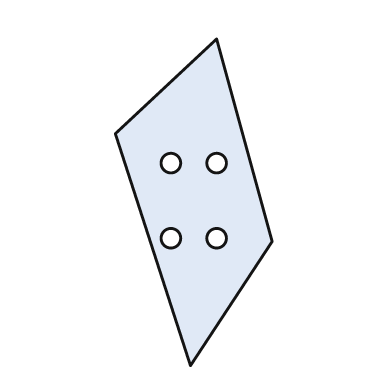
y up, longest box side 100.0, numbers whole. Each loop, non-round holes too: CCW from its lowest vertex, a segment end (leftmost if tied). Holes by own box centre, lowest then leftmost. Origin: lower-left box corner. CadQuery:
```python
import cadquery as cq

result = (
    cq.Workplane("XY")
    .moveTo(23.0, 0.0)
    .lineTo(48.0, 38.0)
    .lineTo(31.0, 100.0)
    .lineTo(0.0, 71.0)
    .close()
    .moveTo(17.0, 39.0)
    .circle(3.0)
    .moveTo(31.0, 39.0)
    .circle(3.0)
    .moveTo(17.0, 62.0)
    .circle(3.0)
    .moveTo(31.0, 62.0)
    .circle(3.0)
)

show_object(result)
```